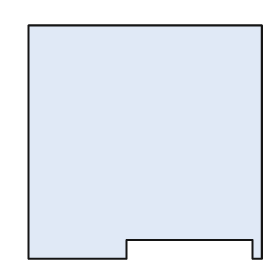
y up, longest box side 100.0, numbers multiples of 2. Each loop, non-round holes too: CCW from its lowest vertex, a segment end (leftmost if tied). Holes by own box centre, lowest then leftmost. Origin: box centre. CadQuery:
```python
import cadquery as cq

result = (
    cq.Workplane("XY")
    .moveTo(-50.0, -50.0)
    .lineTo(-8.0, -50.0)
    .lineTo(-8.0, -42.0)
    .lineTo(46.0, -42.0)
    .lineTo(46.0, -50.0)
    .lineTo(50.0, -50.0)
    .lineTo(50.0, 50.0)
    .lineTo(-50.0, 50.0)
    .close()
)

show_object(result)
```